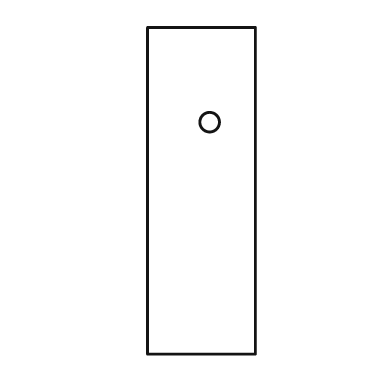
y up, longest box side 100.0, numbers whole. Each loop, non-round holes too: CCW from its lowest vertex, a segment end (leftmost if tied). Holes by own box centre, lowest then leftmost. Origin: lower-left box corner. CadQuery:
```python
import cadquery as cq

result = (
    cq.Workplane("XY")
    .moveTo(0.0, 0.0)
    .lineTo(33.0, 0.0)
    .lineTo(33.0, 100.0)
    .lineTo(0.0, 100.0)
    .close()
    .moveTo(19.0, 71.0)
    .circle(3.0)
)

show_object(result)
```